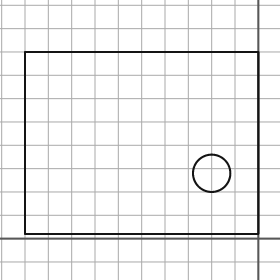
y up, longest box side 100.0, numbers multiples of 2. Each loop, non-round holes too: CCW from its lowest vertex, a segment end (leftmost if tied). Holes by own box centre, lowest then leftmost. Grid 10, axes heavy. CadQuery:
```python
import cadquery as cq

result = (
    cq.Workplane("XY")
    .moveTo(-100.0, 2.0)
    .lineTo(0.0, 2.0)
    .lineTo(0.0, 80.0)
    .lineTo(-100.0, 80.0)
    .close()
    .moveTo(-20.0, 28.0)
    .circle(8.0)
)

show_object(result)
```